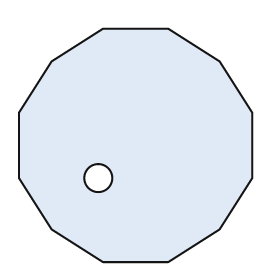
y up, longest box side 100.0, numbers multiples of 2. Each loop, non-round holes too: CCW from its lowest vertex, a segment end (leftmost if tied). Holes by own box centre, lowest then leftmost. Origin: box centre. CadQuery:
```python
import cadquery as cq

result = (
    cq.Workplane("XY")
    .moveTo(-14.0, -50.0)
    .lineTo(14.0, -50.0)
    .lineTo(36.0, -36.0)
    .lineTo(50.0, -14.0)
    .lineTo(50.0, 14.0)
    .lineTo(36.0, 36.0)
    .lineTo(14.0, 50.0)
    .lineTo(-14.0, 50.0)
    .lineTo(-36.0, 36.0)
    .lineTo(-50.0, 14.0)
    .lineTo(-50.0, -14.0)
    .lineTo(-36.0, -36.0)
    .close()
    .moveTo(-16.0, -14.0)
    .circle(6.0)
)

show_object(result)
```